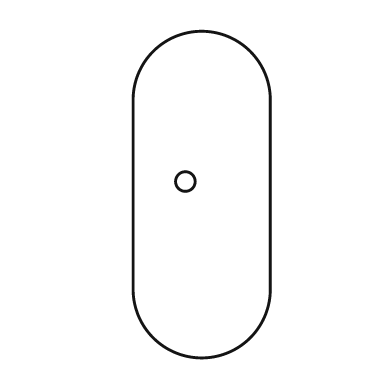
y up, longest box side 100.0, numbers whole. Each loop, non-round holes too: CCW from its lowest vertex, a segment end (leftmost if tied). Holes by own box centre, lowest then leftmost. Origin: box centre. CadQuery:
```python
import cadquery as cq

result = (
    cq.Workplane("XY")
    .moveTo(-21.0, -29.0)
    .threePointArc((0.0, -50.0), (21.0, -29.0))
    .lineTo(21.0, 29.0)
    .threePointArc((0.0, 50.0), (-21.0, 29.0))
    .close()
    .moveTo(-5.0, 4.0)
    .circle(3.0)
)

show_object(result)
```